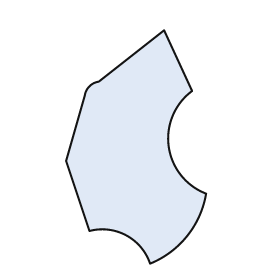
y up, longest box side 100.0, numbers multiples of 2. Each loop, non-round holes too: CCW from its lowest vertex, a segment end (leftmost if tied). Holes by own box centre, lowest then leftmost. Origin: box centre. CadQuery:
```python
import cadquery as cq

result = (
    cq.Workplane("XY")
    .moveTo(6.0, -50.0)
    .threePointArc((22.0, -38.0), (30.0, -20.0))
    .threePointArc((14.0, 0.0), (24.0, 24.0))
    .lineTo(12.0, 50.0)
    .lineTo(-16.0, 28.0)
    .threePointArc((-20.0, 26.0), (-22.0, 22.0))
    .lineTo(-30.0, -6.0)
    .lineTo(-20.0, -36.0)
    .threePointArc((-4.0, -38.0), (6.0, -50.0))
    .close()
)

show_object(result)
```